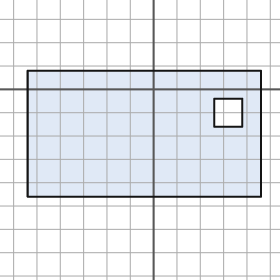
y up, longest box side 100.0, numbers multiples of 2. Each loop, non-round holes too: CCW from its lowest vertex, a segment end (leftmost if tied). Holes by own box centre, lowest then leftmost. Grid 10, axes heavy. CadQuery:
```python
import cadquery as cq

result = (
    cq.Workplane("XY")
    .moveTo(-54.0, -46.0)
    .lineTo(46.0, -46.0)
    .lineTo(46.0, 8.0)
    .lineTo(-54.0, 8.0)
    .close()
    .moveTo(26.0, -16.0)
    .lineTo(38.0, -16.0)
    .lineTo(38.0, -4.0)
    .lineTo(26.0, -4.0)
    .close()
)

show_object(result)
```